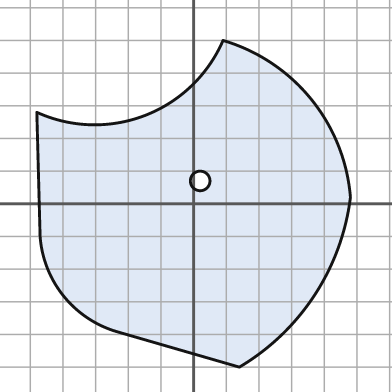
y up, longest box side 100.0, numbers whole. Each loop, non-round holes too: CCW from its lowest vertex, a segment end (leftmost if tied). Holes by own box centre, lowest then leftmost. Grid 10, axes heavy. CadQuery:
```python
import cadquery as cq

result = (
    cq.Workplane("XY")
    .moveTo(14.0, -50.0)
    .threePointArc((37.0, -28.0), (48.0, 2.0))
    .threePointArc((36.0, 32.0), (9.0, 50.0))
    .threePointArc((-15.0, 27.0), (-48.0, 28.0))
    .lineTo(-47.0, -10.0)
    .threePointArc((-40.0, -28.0), (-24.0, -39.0))
    .close()
    .moveTo(2.0, 7.0)
    .circle(3.0)
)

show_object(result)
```